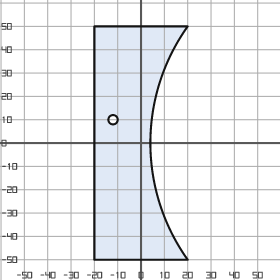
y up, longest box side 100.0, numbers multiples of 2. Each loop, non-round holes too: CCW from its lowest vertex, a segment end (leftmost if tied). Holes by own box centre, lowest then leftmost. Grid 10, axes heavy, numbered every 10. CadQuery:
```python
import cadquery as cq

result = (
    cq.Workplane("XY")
    .moveTo(-20.0, -50.0)
    .lineTo(20.0, -50.0)
    .threePointArc((4.0, 0.0), (20.0, 50.0))
    .lineTo(-20.0, 50.0)
    .close()
    .moveTo(-12.0, 10.0)
    .circle(2.0)
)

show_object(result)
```